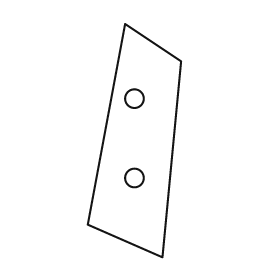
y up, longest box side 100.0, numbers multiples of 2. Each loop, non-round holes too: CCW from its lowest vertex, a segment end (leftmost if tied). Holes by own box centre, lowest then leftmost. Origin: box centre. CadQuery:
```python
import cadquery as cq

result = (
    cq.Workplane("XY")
    .moveTo(12.0, -50.0)
    .lineTo(20.0, 34.0)
    .lineTo(-4.0, 50.0)
    .lineTo(-20.0, -36.0)
    .close()
    .moveTo(0.0, -16.0)
    .circle(4.0)
    .moveTo(0.0, 18.0)
    .circle(4.0)
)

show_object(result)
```